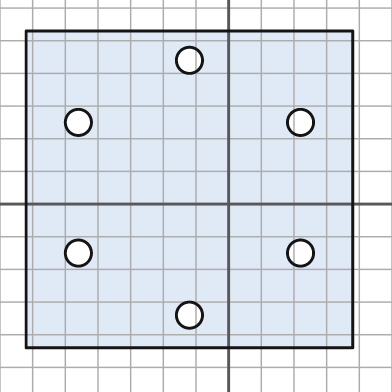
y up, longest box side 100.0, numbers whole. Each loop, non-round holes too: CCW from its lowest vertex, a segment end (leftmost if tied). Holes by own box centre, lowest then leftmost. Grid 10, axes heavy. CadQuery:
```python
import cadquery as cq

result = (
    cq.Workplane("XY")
    .moveTo(-62.0, -44.0)
    .lineTo(38.0, -44.0)
    .lineTo(38.0, 53.0)
    .lineTo(-62.0, 53.0)
    .close()
    .moveTo(-12.0, -34.0)
    .circle(4.0)
    .moveTo(-46.0, -15.0)
    .circle(4.0)
    .moveTo(22.0, -15.0)
    .circle(4.0)
    .moveTo(-46.0, 25.0)
    .circle(4.0)
    .moveTo(22.0, 25.0)
    .circle(4.0)
    .moveTo(-12.0, 44.0)
    .circle(4.0)
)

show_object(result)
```